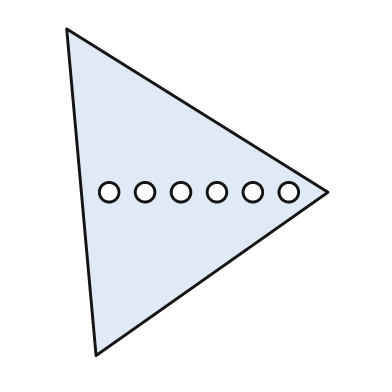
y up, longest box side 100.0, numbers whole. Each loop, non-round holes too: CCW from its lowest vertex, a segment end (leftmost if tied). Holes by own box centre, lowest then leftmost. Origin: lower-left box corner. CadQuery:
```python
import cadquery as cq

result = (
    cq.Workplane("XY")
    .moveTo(9.0, 0.0)
    .lineTo(80.0, 50.0)
    .lineTo(0.0, 100.0)
    .close()
    .moveTo(13.0, 50.0)
    .circle(3.0)
    .moveTo(24.0, 50.0)
    .circle(3.0)
    .moveTo(35.0, 50.0)
    .circle(3.0)
    .moveTo(46.0, 50.0)
    .circle(3.0)
    .moveTo(57.0, 50.0)
    .circle(3.0)
    .moveTo(68.0, 50.0)
    .circle(3.0)
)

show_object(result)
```